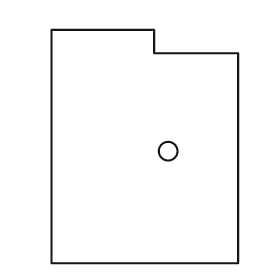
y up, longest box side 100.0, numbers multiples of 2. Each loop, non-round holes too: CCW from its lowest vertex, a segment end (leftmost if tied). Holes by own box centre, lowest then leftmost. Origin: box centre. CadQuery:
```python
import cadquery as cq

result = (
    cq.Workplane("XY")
    .moveTo(-40.0, -50.0)
    .lineTo(40.0, -50.0)
    .lineTo(40.0, 40.0)
    .lineTo(4.0, 40.0)
    .lineTo(4.0, 50.0)
    .lineTo(-40.0, 50.0)
    .close()
    .moveTo(10.0, -2.0)
    .circle(4.0)
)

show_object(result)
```